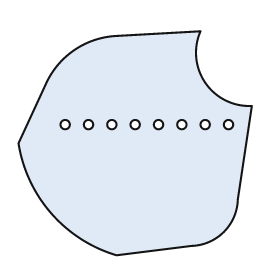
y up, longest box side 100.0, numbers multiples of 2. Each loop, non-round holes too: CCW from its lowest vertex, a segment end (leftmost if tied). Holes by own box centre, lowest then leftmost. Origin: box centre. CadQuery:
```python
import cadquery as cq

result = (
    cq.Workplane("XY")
    .moveTo(-8.0, -48.0)
    .lineTo(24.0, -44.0)
    .threePointArc((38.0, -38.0), (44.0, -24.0))
    .lineTo(50.0, 16.0)
    .threePointArc((30.0, 26.0), (28.0, 48.0))
    .lineTo(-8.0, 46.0)
    .threePointArc((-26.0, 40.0), (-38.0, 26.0))
    .lineTo(-50.0, 0.0)
    .threePointArc((-36.0, -30.0), (-8.0, -48.0))
    .close()
    .moveTo(-30.0, 8.0)
    .circle(2.0)
    .moveTo(-20.0, 8.0)
    .circle(2.0)
    .moveTo(-10.0, 8.0)
    .circle(2.0)
    .moveTo(0.0, 8.0)
    .circle(2.0)
    .moveTo(10.0, 8.0)
    .circle(2.0)
    .moveTo(20.0, 8.0)
    .circle(2.0)
    .moveTo(30.0, 8.0)
    .circle(2.0)
    .moveTo(40.0, 8.0)
    .circle(2.0)
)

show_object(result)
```